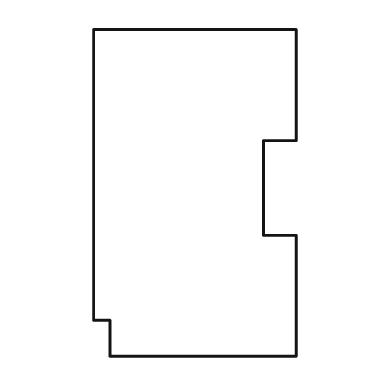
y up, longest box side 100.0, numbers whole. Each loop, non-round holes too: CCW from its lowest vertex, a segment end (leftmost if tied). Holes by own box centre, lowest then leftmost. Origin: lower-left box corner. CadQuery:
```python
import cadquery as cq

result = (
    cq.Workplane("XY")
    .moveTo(5.0, 0.0)
    .lineTo(62.0, 0.0)
    .lineTo(62.0, 37.0)
    .lineTo(52.0, 37.0)
    .lineTo(52.0, 66.0)
    .lineTo(62.0, 66.0)
    .lineTo(62.0, 100.0)
    .lineTo(0.0, 100.0)
    .lineTo(0.0, 11.0)
    .lineTo(5.0, 11.0)
    .close()
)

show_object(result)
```